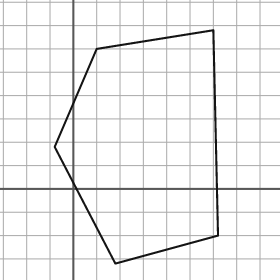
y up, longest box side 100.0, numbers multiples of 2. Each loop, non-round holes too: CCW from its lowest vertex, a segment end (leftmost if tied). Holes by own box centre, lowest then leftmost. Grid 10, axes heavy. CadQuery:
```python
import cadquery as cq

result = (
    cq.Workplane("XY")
    .moveTo(18.0, -32.0)
    .lineTo(62.0, -20.0)
    .lineTo(60.0, 68.0)
    .lineTo(10.0, 60.0)
    .lineTo(-8.0, 18.0)
    .close()
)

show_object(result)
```